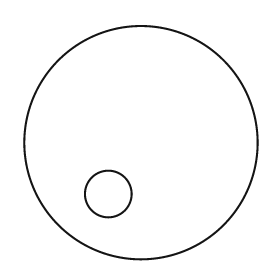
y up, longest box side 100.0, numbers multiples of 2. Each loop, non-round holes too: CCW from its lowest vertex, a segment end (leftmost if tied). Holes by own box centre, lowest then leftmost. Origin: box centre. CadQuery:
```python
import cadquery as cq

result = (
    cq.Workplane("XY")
    .moveTo(0.0, 0.0)
    .circle(50.0)
    .moveTo(-14.0, -22.0)
    .circle(10.0)
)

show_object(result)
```